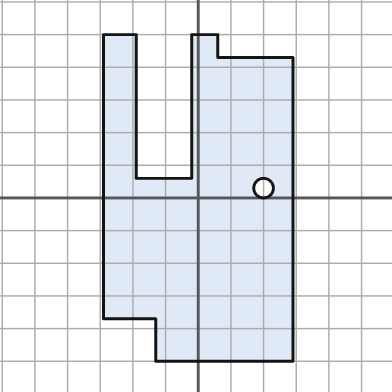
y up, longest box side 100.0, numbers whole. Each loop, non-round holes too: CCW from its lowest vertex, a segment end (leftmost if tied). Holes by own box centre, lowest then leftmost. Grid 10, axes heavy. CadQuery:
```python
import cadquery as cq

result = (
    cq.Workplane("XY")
    .moveTo(-13.0, -50.0)
    .lineTo(29.0, -50.0)
    .lineTo(29.0, 43.0)
    .lineTo(6.0, 43.0)
    .lineTo(6.0, 50.0)
    .lineTo(-2.0, 50.0)
    .lineTo(-2.0, 6.0)
    .lineTo(-19.0, 6.0)
    .lineTo(-19.0, 50.0)
    .lineTo(-29.0, 50.0)
    .lineTo(-29.0, -37.0)
    .lineTo(-13.0, -37.0)
    .close()
    .moveTo(20.0, 3.0)
    .circle(3.0)
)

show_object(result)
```